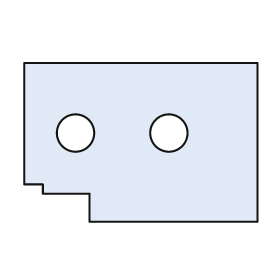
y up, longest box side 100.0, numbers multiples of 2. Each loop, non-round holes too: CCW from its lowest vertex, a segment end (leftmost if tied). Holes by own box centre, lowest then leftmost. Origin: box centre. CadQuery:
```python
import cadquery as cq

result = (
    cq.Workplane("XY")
    .moveTo(-22.0, -34.0)
    .lineTo(50.0, -34.0)
    .lineTo(50.0, 34.0)
    .lineTo(-50.0, 34.0)
    .lineTo(-50.0, -18.0)
    .lineTo(-42.0, -18.0)
    .lineTo(-42.0, -22.0)
    .lineTo(-22.0, -22.0)
    .close()
    .moveTo(-28.0, 4.0)
    .circle(8.0)
    .moveTo(12.0, 4.0)
    .circle(8.0)
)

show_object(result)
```